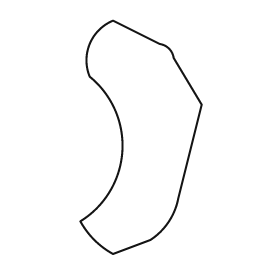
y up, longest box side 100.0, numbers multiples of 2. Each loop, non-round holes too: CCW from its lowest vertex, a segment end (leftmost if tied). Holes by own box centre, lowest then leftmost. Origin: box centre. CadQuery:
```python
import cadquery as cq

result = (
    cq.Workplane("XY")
    .moveTo(-12.0, -50.0)
    .lineTo(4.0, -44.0)
    .threePointArc((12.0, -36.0), (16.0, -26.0))
    .lineTo(26.0, 14.0)
    .lineTo(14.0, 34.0)
    .threePointArc((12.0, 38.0), (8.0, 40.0))
    .lineTo(-12.0, 50.0)
    .threePointArc((-22.0, 40.0), (-22.0, 26.0))
    .threePointArc((-8.0, -6.0), (-26.0, -36.0))
    .threePointArc((-20.0, -44.0), (-12.0, -50.0))
    .close()
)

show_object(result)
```